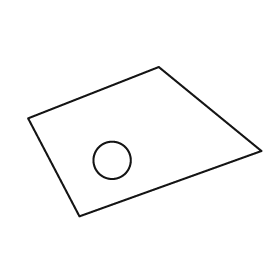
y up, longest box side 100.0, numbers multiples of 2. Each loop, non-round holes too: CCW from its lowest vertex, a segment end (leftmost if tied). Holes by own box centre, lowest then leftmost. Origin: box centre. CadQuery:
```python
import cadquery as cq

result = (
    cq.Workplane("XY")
    .moveTo(-28.0, -32.0)
    .lineTo(50.0, -4.0)
    .lineTo(6.0, 32.0)
    .lineTo(-50.0, 10.0)
    .close()
    .moveTo(-14.0, -8.0)
    .circle(8.0)
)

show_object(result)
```